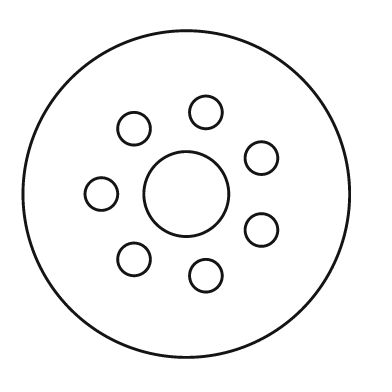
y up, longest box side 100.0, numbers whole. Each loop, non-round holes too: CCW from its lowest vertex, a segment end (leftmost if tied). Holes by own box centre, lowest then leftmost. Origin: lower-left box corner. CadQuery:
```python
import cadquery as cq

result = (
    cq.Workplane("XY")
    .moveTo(50.0, 50.0)
    .circle(50.0)
    .moveTo(56.0, 25.0)
    .circle(5.0)
    .moveTo(34.0, 30.0)
    .circle(5.0)
    .moveTo(73.0, 39.0)
    .circle(5.0)
    .moveTo(24.0, 50.0)
    .circle(5.0)
    .moveTo(50.0, 50.0)
    .circle(13.0)
    .moveTo(73.0, 61.0)
    .circle(5.0)
    .moveTo(34.0, 70.0)
    .circle(5.0)
    .moveTo(56.0, 75.0)
    .circle(5.0)
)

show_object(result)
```